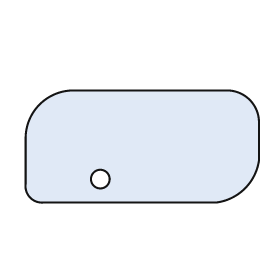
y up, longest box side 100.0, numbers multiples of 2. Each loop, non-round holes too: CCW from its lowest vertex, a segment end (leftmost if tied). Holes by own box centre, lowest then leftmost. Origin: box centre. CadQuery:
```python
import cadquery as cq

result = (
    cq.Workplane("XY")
    .moveTo(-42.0, -24.0)
    .lineTo(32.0, -24.0)
    .threePointArc((44.0, -18.0), (50.0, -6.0))
    .lineTo(50.0, 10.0)
    .threePointArc((46.0, 20.0), (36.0, 24.0))
    .lineTo(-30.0, 24.0)
    .threePointArc((-44.0, 18.0), (-50.0, 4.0))
    .lineTo(-50.0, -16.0)
    .threePointArc((-48.0, -22.0), (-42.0, -24.0))
    .close()
    .moveTo(-18.0, -14.0)
    .circle(4.0)
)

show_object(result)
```